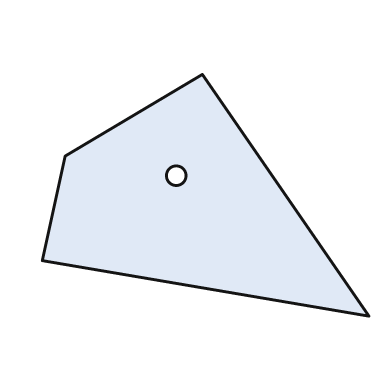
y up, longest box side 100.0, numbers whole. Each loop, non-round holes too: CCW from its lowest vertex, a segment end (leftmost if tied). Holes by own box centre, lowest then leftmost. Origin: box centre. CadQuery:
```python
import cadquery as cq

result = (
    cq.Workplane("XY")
    .moveTo(50.0, -37.0)
    .lineTo(-1.0, 37.0)
    .lineTo(-43.0, 12.0)
    .lineTo(-50.0, -20.0)
    .close()
    .moveTo(-9.0, 6.0)
    .circle(3.0)
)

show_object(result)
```